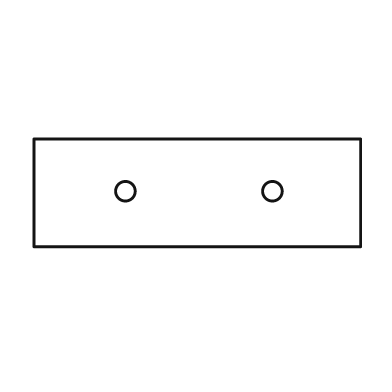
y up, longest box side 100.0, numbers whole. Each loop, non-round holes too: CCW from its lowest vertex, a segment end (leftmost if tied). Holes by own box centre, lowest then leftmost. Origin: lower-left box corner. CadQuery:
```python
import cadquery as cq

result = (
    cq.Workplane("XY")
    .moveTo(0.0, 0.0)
    .lineTo(100.0, 0.0)
    .lineTo(100.0, 33.0)
    .lineTo(0.0, 33.0)
    .close()
    .moveTo(28.0, 17.0)
    .circle(3.0)
    .moveTo(73.0, 17.0)
    .circle(3.0)
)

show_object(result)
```